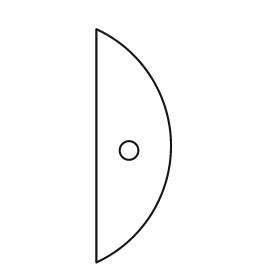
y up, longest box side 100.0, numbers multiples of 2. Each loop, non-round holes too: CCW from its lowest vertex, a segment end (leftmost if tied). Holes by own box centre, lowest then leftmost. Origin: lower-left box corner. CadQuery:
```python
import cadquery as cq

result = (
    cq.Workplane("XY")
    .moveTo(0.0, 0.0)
    .threePointArc((32.0, 50.0), (0.0, 100.0))
    .close()
    .moveTo(14.0, 48.0)
    .circle(4.0)
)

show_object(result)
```